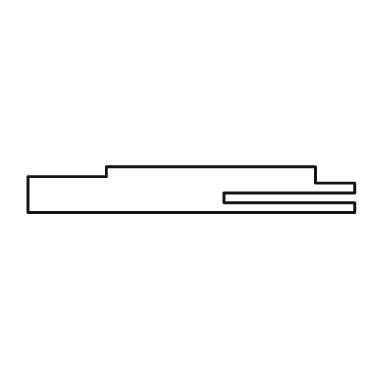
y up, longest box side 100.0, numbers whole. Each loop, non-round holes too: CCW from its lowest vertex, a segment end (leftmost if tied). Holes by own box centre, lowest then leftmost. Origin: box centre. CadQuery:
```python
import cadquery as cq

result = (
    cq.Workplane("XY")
    .moveTo(-50.0, -7.0)
    .lineTo(50.0, -7.0)
    .lineTo(50.0, -4.0)
    .lineTo(10.0, -4.0)
    .lineTo(10.0, -1.0)
    .lineTo(50.0, -1.0)
    .lineTo(50.0, 2.0)
    .lineTo(38.0, 2.0)
    .lineTo(38.0, 7.0)
    .lineTo(-26.0, 7.0)
    .lineTo(-26.0, 4.0)
    .lineTo(-50.0, 4.0)
    .close()
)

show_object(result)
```